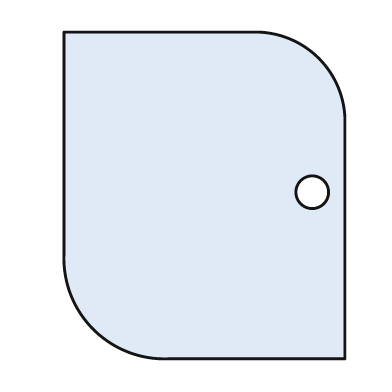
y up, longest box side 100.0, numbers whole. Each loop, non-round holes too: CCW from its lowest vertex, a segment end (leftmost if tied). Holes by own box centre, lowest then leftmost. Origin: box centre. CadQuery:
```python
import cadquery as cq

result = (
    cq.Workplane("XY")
    .moveTo(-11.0, -50.0)
    .lineTo(43.0, -50.0)
    .lineTo(43.0, 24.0)
    .threePointArc((35.0, 42.0), (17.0, 50.0))
    .lineTo(-43.0, 50.0)
    .lineTo(-43.0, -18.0)
    .threePointArc((-34.0, -41.0), (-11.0, -50.0))
    .close()
    .moveTo(33.0, 1.0)
    .circle(5.0)
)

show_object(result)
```